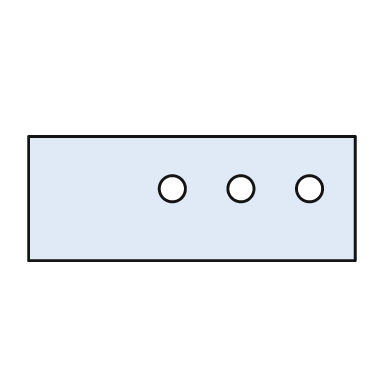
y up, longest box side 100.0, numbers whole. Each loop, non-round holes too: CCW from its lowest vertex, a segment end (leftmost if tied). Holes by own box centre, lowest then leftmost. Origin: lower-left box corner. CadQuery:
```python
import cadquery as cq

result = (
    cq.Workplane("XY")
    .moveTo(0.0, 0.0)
    .lineTo(100.0, 0.0)
    .lineTo(100.0, 38.0)
    .lineTo(0.0, 38.0)
    .close()
    .moveTo(44.0, 22.0)
    .circle(4.0)
    .moveTo(65.0, 22.0)
    .circle(4.0)
    .moveTo(86.0, 22.0)
    .circle(4.0)
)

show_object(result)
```